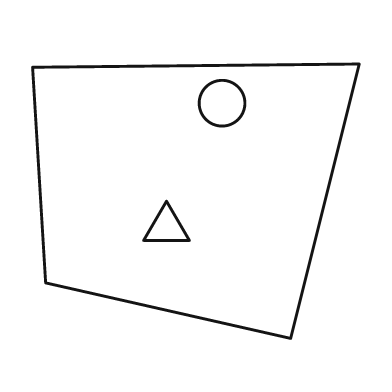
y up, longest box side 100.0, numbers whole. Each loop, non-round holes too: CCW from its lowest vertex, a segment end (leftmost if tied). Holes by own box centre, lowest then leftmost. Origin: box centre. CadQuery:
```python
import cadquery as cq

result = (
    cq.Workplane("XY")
    .moveTo(29.0, -42.0)
    .lineTo(50.0, 42.0)
    .lineTo(-50.0, 41.0)
    .lineTo(-46.0, -25.0)
    .close()
    .moveTo(-16.0, -12.0)
    .lineTo(-2.0, -12.0)
    .lineTo(-9.0, 0.0)
    .close()
    .moveTo(8.0, 30.0)
    .circle(7.0)
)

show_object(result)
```